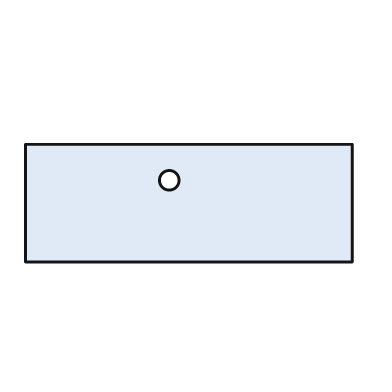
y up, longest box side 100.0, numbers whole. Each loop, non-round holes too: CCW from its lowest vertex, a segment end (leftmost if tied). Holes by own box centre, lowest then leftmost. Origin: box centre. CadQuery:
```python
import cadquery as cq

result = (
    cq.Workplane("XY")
    .moveTo(-50.0, -18.0)
    .lineTo(50.0, -18.0)
    .lineTo(50.0, 18.0)
    .lineTo(-50.0, 18.0)
    .close()
    .moveTo(-6.0, 7.0)
    .circle(3.0)
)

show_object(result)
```